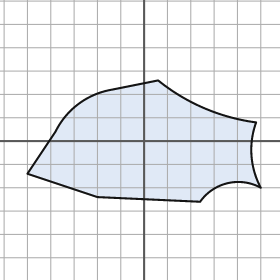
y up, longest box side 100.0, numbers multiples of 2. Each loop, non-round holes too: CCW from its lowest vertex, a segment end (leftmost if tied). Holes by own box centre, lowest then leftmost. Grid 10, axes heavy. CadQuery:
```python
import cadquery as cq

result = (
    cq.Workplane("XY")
    .moveTo(24.0, -26.0)
    .threePointArc((36.0, -18.0), (50.0, -20.0))
    .threePointArc((46.0, -6.0), (48.0, 8.0))
    .threePointArc((26.0, 14.0), (6.0, 26.0))
    .lineTo(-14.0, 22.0)
    .threePointArc((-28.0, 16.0), (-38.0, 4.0))
    .lineTo(-50.0, -14.0)
    .lineTo(-20.0, -24.0)
    .close()
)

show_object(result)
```